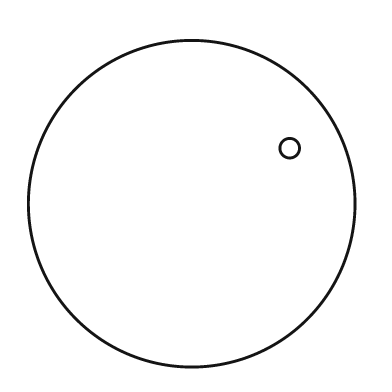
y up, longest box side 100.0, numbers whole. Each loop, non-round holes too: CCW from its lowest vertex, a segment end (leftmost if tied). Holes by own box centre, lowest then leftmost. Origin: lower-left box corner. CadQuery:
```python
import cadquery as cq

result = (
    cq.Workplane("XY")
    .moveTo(50.0, 50.0)
    .circle(50.0)
    .moveTo(80.0, 67.0)
    .circle(3.0)
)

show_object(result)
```